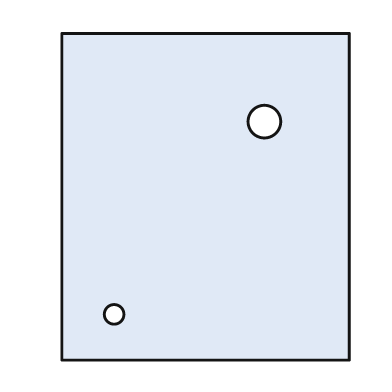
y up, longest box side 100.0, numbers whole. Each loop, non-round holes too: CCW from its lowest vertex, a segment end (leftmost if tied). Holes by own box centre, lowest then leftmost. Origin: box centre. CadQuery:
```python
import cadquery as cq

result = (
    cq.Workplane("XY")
    .moveTo(-44.0, -50.0)
    .lineTo(44.0, -50.0)
    .lineTo(44.0, 50.0)
    .lineTo(-44.0, 50.0)
    .close()
    .moveTo(-28.0, -36.0)
    .circle(3.0)
    .moveTo(18.0, 23.0)
    .circle(5.0)
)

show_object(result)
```